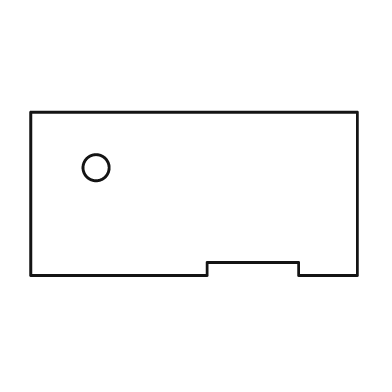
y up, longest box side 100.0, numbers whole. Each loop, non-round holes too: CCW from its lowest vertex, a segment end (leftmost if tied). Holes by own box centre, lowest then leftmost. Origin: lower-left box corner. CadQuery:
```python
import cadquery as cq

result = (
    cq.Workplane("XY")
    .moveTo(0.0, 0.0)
    .lineTo(54.0, 0.0)
    .lineTo(54.0, 4.0)
    .lineTo(82.0, 4.0)
    .lineTo(82.0, 0.0)
    .lineTo(100.0, 0.0)
    .lineTo(100.0, 50.0)
    .lineTo(0.0, 50.0)
    .close()
    .moveTo(20.0, 33.0)
    .circle(4.0)
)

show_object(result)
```